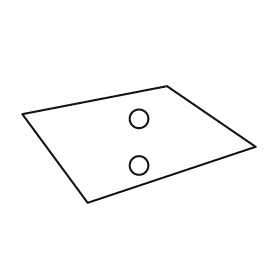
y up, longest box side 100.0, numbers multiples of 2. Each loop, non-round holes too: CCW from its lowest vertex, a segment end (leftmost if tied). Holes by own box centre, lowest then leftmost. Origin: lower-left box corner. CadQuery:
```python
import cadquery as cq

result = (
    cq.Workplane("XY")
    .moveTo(28.0, 0.0)
    .lineTo(100.0, 24.0)
    .lineTo(62.0, 50.0)
    .lineTo(0.0, 38.0)
    .close()
    .moveTo(50.0, 16.0)
    .circle(4.0)
    .moveTo(50.0, 36.0)
    .circle(4.0)
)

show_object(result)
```